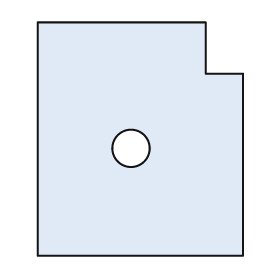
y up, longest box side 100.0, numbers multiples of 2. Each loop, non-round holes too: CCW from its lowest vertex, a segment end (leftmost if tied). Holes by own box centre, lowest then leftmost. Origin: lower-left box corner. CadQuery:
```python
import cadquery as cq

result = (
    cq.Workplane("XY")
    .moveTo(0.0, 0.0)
    .lineTo(88.0, 0.0)
    .lineTo(88.0, 78.0)
    .lineTo(72.0, 78.0)
    .lineTo(72.0, 100.0)
    .lineTo(0.0, 100.0)
    .close()
    .moveTo(40.0, 46.0)
    .circle(8.0)
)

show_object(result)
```